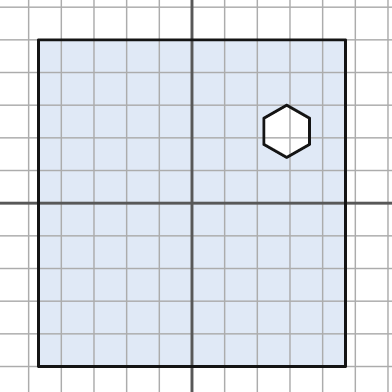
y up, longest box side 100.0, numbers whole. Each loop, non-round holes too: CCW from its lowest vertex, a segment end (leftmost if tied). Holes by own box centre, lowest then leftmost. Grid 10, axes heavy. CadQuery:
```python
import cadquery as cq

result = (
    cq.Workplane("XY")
    .moveTo(-47.0, -50.0)
    .lineTo(47.0, -50.0)
    .lineTo(47.0, 50.0)
    .lineTo(-47.0, 50.0)
    .close()
    .moveTo(29.0, 14.0)
    .lineTo(36.0, 18.0)
    .lineTo(36.0, 26.0)
    .lineTo(29.0, 30.0)
    .lineTo(22.0, 26.0)
    .lineTo(22.0, 18.0)
    .close()
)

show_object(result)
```